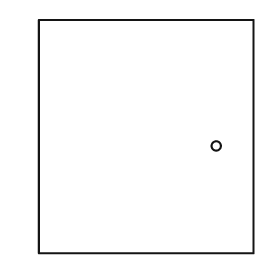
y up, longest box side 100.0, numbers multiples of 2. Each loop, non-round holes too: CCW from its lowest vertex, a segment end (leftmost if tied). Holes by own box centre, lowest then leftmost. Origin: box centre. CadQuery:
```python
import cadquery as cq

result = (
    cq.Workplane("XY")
    .moveTo(-46.0, -50.0)
    .lineTo(46.0, -50.0)
    .lineTo(46.0, 50.0)
    .lineTo(-46.0, 50.0)
    .close()
    .moveTo(30.0, -4.0)
    .circle(2.0)
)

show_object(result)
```